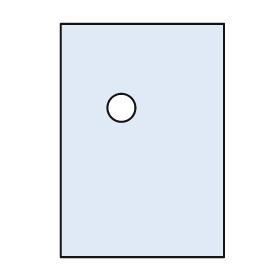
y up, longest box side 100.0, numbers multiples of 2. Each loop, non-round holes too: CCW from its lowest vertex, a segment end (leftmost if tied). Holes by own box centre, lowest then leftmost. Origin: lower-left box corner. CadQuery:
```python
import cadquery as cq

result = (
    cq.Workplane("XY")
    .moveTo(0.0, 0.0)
    .lineTo(70.0, 0.0)
    .lineTo(70.0, 100.0)
    .lineTo(0.0, 100.0)
    .close()
    .moveTo(26.0, 64.0)
    .circle(6.0)
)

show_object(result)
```